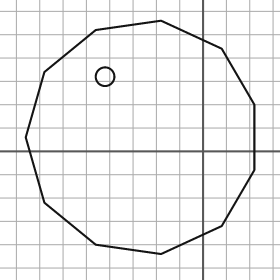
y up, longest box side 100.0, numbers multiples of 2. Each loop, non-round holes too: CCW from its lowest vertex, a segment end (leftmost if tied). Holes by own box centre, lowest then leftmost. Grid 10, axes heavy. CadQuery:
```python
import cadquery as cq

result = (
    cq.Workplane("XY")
    .moveTo(-18.0, -44.0)
    .lineTo(8.0, -32.0)
    .lineTo(22.0, -8.0)
    .lineTo(22.0, 20.0)
    .lineTo(8.0, 44.0)
    .lineTo(-18.0, 56.0)
    .lineTo(-46.0, 52.0)
    .lineTo(-68.0, 34.0)
    .lineTo(-76.0, 6.0)
    .lineTo(-68.0, -22.0)
    .lineTo(-46.0, -40.0)
    .close()
    .moveTo(-42.0, 32.0)
    .circle(4.0)
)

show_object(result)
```